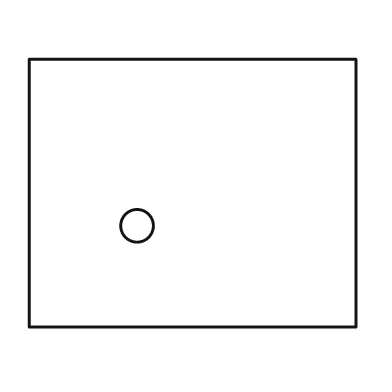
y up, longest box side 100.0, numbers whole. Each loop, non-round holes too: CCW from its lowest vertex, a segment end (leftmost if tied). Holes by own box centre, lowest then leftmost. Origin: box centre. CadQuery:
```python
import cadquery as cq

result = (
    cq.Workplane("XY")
    .moveTo(-50.0, -41.0)
    .lineTo(50.0, -41.0)
    .lineTo(50.0, 41.0)
    .lineTo(-50.0, 41.0)
    .close()
    .moveTo(-17.0, -10.0)
    .circle(5.0)
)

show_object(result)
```